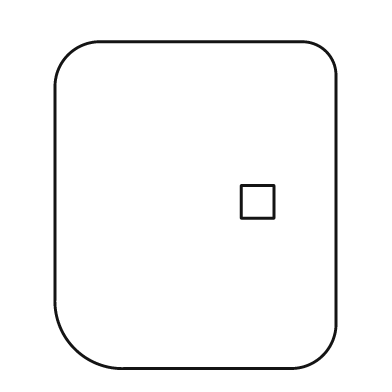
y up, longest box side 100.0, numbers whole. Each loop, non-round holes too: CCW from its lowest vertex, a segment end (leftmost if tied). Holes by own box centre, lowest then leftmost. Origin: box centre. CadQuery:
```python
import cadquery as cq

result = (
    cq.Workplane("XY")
    .moveTo(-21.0, -50.0)
    .lineTo(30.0, -50.0)
    .threePointArc((39.0, -46.0), (43.0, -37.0))
    .lineTo(43.0, 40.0)
    .threePointArc((40.0, 47.0), (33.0, 50.0))
    .lineTo(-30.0, 50.0)
    .threePointArc((-39.0, 46.0), (-43.0, 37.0))
    .lineTo(-43.0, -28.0)
    .threePointArc((-37.0, -44.0), (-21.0, -50.0))
    .close()
    .moveTo(14.0, -4.0)
    .lineTo(24.0, -4.0)
    .lineTo(24.0, 6.0)
    .lineTo(14.0, 6.0)
    .close()
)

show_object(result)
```